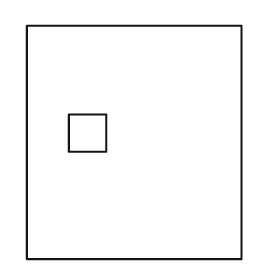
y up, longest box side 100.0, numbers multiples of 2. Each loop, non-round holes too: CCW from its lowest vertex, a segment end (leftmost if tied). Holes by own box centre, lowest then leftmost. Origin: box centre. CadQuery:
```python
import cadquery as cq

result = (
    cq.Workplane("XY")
    .moveTo(-46.0, -50.0)
    .lineTo(46.0, -50.0)
    .lineTo(46.0, 50.0)
    .lineTo(-46.0, 50.0)
    .close()
    .moveTo(-28.0, -4.0)
    .lineTo(-12.0, -4.0)
    .lineTo(-12.0, 12.0)
    .lineTo(-28.0, 12.0)
    .close()
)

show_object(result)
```